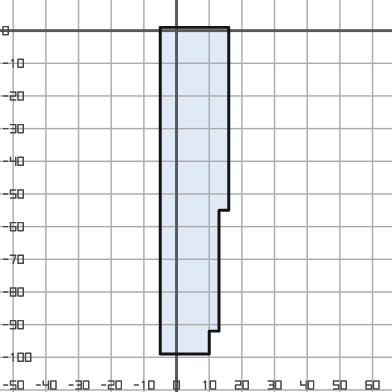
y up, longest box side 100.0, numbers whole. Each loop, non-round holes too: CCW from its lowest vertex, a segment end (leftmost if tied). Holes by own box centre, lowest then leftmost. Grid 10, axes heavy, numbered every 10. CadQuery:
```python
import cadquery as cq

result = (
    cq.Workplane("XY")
    .moveTo(-5.0, -99.0)
    .lineTo(10.0, -99.0)
    .lineTo(10.0, -92.0)
    .lineTo(13.0, -92.0)
    .lineTo(13.0, -55.0)
    .lineTo(16.0, -55.0)
    .lineTo(16.0, 1.0)
    .lineTo(-5.0, 1.0)
    .close()
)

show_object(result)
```